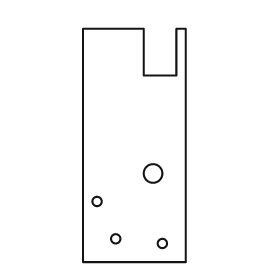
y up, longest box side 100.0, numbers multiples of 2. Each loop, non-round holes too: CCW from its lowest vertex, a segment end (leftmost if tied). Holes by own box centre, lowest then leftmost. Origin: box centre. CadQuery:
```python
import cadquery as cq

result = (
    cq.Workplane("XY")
    .moveTo(-22.0, -50.0)
    .lineTo(22.0, -50.0)
    .lineTo(22.0, 50.0)
    .lineTo(18.0, 50.0)
    .lineTo(18.0, 30.0)
    .lineTo(4.0, 30.0)
    .lineTo(4.0, 50.0)
    .lineTo(-22.0, 50.0)
    .close()
    .moveTo(12.0, -42.0)
    .circle(2.0)
    .moveTo(-8.0, -40.0)
    .circle(2.0)
    .moveTo(-16.0, -24.0)
    .circle(2.0)
    .moveTo(8.0, -12.0)
    .circle(4.0)
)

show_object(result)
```